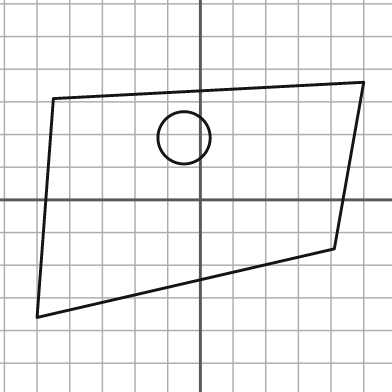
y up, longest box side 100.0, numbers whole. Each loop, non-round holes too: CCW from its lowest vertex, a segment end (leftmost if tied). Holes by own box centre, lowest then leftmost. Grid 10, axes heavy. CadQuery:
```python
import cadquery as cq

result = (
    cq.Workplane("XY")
    .moveTo(-50.0, -36.0)
    .lineTo(41.0, -15.0)
    .lineTo(50.0, 36.0)
    .lineTo(-45.0, 31.0)
    .close()
    .moveTo(-5.0, 19.0)
    .circle(8.0)
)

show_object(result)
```